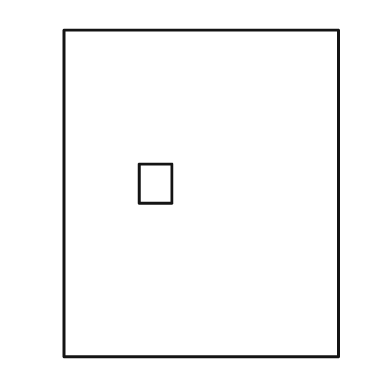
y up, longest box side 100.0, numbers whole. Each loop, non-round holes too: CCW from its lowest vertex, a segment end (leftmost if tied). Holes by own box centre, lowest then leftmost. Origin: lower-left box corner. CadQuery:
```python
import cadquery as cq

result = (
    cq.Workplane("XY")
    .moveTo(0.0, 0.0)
    .lineTo(84.0, 0.0)
    .lineTo(84.0, 100.0)
    .lineTo(0.0, 100.0)
    .close()
    .moveTo(23.0, 47.0)
    .lineTo(33.0, 47.0)
    .lineTo(33.0, 59.0)
    .lineTo(23.0, 59.0)
    .close()
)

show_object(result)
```